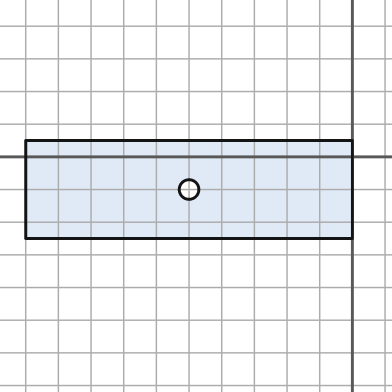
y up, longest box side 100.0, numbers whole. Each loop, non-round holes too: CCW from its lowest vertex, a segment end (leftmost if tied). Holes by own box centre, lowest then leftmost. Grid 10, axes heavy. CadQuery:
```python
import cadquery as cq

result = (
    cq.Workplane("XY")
    .moveTo(-100.0, -25.0)
    .lineTo(0.0, -25.0)
    .lineTo(0.0, 5.0)
    .lineTo(-100.0, 5.0)
    .close()
    .moveTo(-50.0, -10.0)
    .circle(3.0)
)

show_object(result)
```